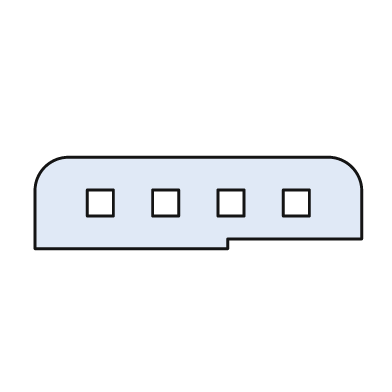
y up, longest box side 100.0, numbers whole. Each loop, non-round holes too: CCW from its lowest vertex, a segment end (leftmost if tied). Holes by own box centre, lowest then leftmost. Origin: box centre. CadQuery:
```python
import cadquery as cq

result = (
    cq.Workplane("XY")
    .moveTo(-50.0, -14.0)
    .lineTo(9.0, -14.0)
    .lineTo(9.0, -11.0)
    .lineTo(50.0, -11.0)
    .lineTo(50.0, 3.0)
    .threePointArc((47.0, 11.0), (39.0, 14.0))
    .lineTo(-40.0, 14.0)
    .threePointArc((-47.0, 11.0), (-50.0, 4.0))
    .close()
    .moveTo(-34.0, -4.0)
    .lineTo(-26.0, -4.0)
    .lineTo(-26.0, 4.0)
    .lineTo(-34.0, 4.0)
    .close()
    .moveTo(-14.0, -4.0)
    .lineTo(-6.0, -4.0)
    .lineTo(-6.0, 4.0)
    .lineTo(-14.0, 4.0)
    .close()
    .moveTo(6.0, -4.0)
    .lineTo(14.0, -4.0)
    .lineTo(14.0, 4.0)
    .lineTo(6.0, 4.0)
    .close()
    .moveTo(26.0, -4.0)
    .lineTo(34.0, -4.0)
    .lineTo(34.0, 4.0)
    .lineTo(26.0, 4.0)
    .close()
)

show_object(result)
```